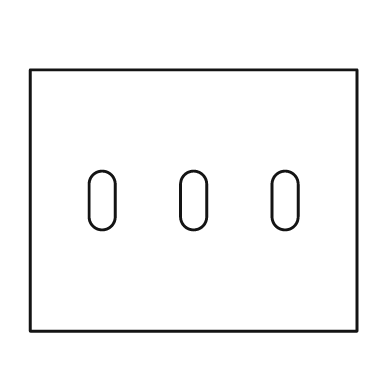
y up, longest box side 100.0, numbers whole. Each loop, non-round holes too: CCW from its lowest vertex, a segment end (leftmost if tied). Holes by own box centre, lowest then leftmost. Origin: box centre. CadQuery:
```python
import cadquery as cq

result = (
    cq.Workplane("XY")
    .moveTo(-50.0, -40.0)
    .lineTo(50.0, -40.0)
    .lineTo(50.0, 40.0)
    .lineTo(-50.0, 40.0)
    .close()
    .moveTo(-32.0, -5.0)
    .threePointArc((-28.0, -9.0), (-24.0, -5.0))
    .lineTo(-24.0, 5.0)
    .threePointArc((-28.0, 9.0), (-32.0, 5.0))
    .close()
    .moveTo(-4.0, -5.0)
    .threePointArc((0.0, -9.0), (4.0, -5.0))
    .lineTo(4.0, 5.0)
    .threePointArc((0.0, 9.0), (-4.0, 5.0))
    .close()
    .moveTo(24.0, -5.0)
    .threePointArc((28.0, -9.0), (32.0, -5.0))
    .lineTo(32.0, 5.0)
    .threePointArc((28.0, 9.0), (24.0, 5.0))
    .close()
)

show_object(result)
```